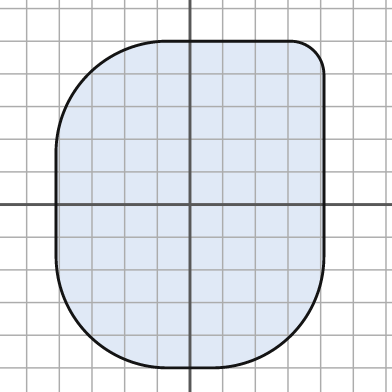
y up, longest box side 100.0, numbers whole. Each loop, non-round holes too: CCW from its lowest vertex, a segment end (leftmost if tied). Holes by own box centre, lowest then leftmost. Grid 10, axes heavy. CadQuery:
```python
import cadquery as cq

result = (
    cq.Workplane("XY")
    .moveTo(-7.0, -50.0)
    .lineTo(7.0, -50.0)
    .threePointArc((31.0, -40.0), (41.0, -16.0))
    .lineTo(41.0, 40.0)
    .threePointArc((38.0, 47.0), (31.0, 50.0))
    .lineTo(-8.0, 50.0)
    .threePointArc((-31.0, 40.0), (-41.0, 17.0))
    .lineTo(-41.0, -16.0)
    .threePointArc((-31.0, -40.0), (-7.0, -50.0))
    .close()
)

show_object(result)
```